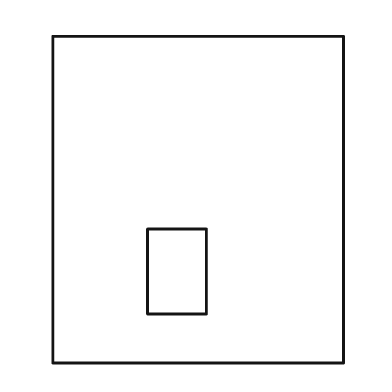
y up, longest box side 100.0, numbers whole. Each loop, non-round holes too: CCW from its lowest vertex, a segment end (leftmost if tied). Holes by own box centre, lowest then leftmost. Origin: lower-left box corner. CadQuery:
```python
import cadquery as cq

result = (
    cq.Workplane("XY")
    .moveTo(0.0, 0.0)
    .lineTo(89.0, 0.0)
    .lineTo(89.0, 100.0)
    .lineTo(0.0, 100.0)
    .close()
    .moveTo(29.0, 15.0)
    .lineTo(47.0, 15.0)
    .lineTo(47.0, 41.0)
    .lineTo(29.0, 41.0)
    .close()
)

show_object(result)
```